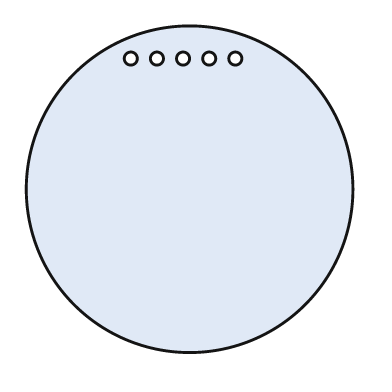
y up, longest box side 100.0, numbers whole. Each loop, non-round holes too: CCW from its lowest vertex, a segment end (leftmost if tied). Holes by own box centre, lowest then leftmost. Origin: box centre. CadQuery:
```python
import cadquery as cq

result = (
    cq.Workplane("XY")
    .moveTo(0.0, 0.0)
    .circle(50.0)
    .moveTo(-18.0, 40.0)
    .circle(2.0)
    .moveTo(-10.0, 40.0)
    .circle(2.0)
    .moveTo(-2.0, 40.0)
    .circle(2.0)
    .moveTo(6.0, 40.0)
    .circle(2.0)
    .moveTo(14.0, 40.0)
    .circle(2.0)
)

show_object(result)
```